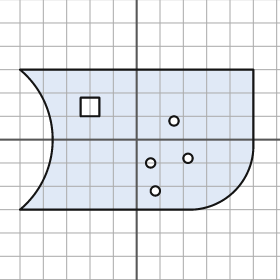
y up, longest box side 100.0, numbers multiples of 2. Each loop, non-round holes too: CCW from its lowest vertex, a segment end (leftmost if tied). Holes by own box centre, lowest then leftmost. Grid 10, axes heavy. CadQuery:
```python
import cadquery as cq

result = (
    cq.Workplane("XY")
    .moveTo(-50.0, -30.0)
    .lineTo(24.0, -30.0)
    .threePointArc((42.0, -22.0), (50.0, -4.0))
    .lineTo(50.0, 30.0)
    .lineTo(-50.0, 30.0)
    .threePointArc((-36.0, 0.0), (-50.0, -30.0))
    .close()
    .moveTo(8.0, -22.0)
    .circle(2.0)
    .moveTo(6.0, -10.0)
    .circle(2.0)
    .moveTo(22.0, -8.0)
    .circle(2.0)
    .moveTo(16.0, 8.0)
    .circle(2.0)
    .moveTo(-24.0, 10.0)
    .lineTo(-16.0, 10.0)
    .lineTo(-16.0, 18.0)
    .lineTo(-24.0, 18.0)
    .close()
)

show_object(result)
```